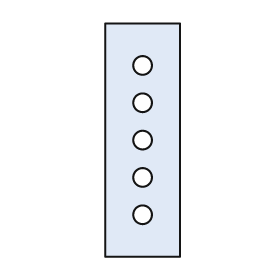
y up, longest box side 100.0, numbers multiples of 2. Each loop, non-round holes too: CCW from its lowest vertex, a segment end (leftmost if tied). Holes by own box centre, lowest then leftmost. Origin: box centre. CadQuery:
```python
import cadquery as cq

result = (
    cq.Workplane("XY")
    .moveTo(-16.0, -50.0)
    .lineTo(16.0, -50.0)
    .lineTo(16.0, 50.0)
    .lineTo(-16.0, 50.0)
    .close()
    .moveTo(0.0, -32.0)
    .circle(4.0)
    .moveTo(0.0, -16.0)
    .circle(4.0)
    .moveTo(0.0, 0.0)
    .circle(4.0)
    .moveTo(0.0, 16.0)
    .circle(4.0)
    .moveTo(0.0, 32.0)
    .circle(4.0)
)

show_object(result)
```